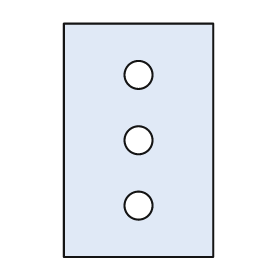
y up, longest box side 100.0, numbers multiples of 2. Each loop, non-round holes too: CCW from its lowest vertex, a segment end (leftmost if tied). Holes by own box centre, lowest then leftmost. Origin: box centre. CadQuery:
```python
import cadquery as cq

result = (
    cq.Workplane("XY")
    .moveTo(-32.0, -50.0)
    .lineTo(32.0, -50.0)
    .lineTo(32.0, 50.0)
    .lineTo(-32.0, 50.0)
    .close()
    .moveTo(0.0, -28.0)
    .circle(6.0)
    .moveTo(0.0, 0.0)
    .circle(6.0)
    .moveTo(0.0, 28.0)
    .circle(6.0)
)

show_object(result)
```